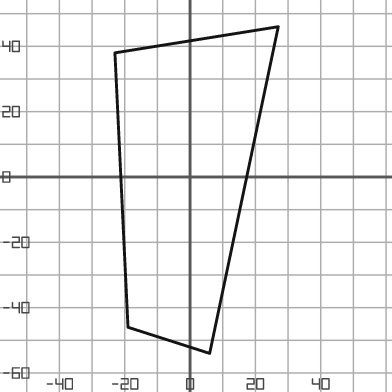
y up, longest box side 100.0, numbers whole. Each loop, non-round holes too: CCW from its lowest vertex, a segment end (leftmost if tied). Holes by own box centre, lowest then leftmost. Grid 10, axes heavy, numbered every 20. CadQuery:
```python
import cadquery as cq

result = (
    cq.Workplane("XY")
    .moveTo(6.0, -54.0)
    .lineTo(27.0, 46.0)
    .lineTo(-23.0, 38.0)
    .lineTo(-19.0, -46.0)
    .close()
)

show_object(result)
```